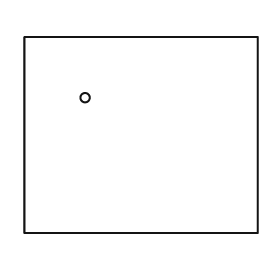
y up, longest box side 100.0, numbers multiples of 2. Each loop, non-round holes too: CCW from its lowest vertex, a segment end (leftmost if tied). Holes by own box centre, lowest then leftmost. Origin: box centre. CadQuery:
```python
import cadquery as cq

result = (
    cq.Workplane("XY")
    .moveTo(-50.0, -42.0)
    .lineTo(50.0, -42.0)
    .lineTo(50.0, 42.0)
    .lineTo(-50.0, 42.0)
    .close()
    .moveTo(-24.0, 16.0)
    .circle(2.0)
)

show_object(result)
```